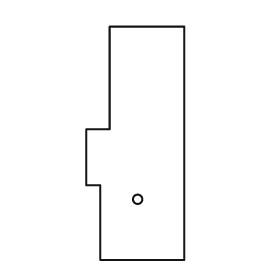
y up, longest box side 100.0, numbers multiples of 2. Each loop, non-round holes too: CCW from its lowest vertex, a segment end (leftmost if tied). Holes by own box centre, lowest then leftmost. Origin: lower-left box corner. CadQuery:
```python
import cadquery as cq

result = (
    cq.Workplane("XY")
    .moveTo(6.0, 0.0)
    .lineTo(42.0, 0.0)
    .lineTo(42.0, 100.0)
    .lineTo(10.0, 100.0)
    .lineTo(10.0, 56.0)
    .lineTo(0.0, 56.0)
    .lineTo(0.0, 32.0)
    .lineTo(6.0, 32.0)
    .close()
    .moveTo(22.0, 26.0)
    .circle(2.0)
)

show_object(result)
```